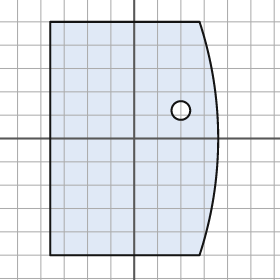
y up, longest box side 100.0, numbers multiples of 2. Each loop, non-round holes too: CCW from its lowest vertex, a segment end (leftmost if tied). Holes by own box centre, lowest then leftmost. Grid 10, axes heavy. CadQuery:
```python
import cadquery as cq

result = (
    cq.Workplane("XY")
    .moveTo(-36.0, -50.0)
    .lineTo(28.0, -50.0)
    .threePointArc((36.0, 0.0), (28.0, 50.0))
    .lineTo(-36.0, 50.0)
    .close()
    .moveTo(20.0, 12.0)
    .circle(4.0)
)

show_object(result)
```